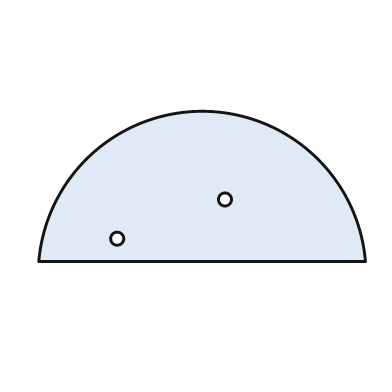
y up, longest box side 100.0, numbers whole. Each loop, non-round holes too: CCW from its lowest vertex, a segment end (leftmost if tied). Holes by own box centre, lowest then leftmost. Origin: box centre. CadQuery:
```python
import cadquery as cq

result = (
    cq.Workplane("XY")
    .moveTo(-50.0, -23.0)
    .lineTo(50.0, -23.0)
    .threePointArc((0.0, 23.0), (-50.0, -23.0))
    .close()
    .moveTo(-26.0, -16.0)
    .circle(2.0)
    .moveTo(7.0, -4.0)
    .circle(2.0)
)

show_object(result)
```